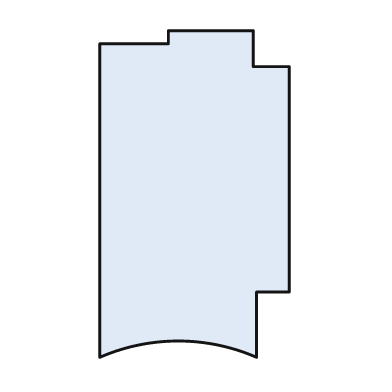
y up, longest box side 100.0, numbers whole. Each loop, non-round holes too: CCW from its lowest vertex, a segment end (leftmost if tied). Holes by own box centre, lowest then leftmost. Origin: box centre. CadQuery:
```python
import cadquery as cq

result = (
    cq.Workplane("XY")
    .moveTo(-29.0, -50.0)
    .threePointArc((-5.0, -45.0), (19.0, -50.0))
    .lineTo(19.0, -30.0)
    .lineTo(29.0, -30.0)
    .lineTo(29.0, 39.0)
    .lineTo(18.0, 39.0)
    .lineTo(18.0, 50.0)
    .lineTo(-8.0, 50.0)
    .lineTo(-8.0, 46.0)
    .lineTo(-29.0, 46.0)
    .close()
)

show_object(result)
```